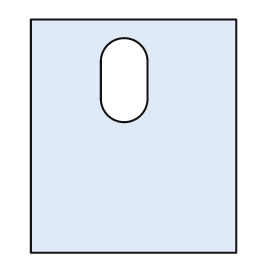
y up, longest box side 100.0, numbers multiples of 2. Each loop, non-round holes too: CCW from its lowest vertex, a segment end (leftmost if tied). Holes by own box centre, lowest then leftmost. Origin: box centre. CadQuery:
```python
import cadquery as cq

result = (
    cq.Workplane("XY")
    .moveTo(-44.0, -50.0)
    .lineTo(44.0, -50.0)
    .lineTo(44.0, 50.0)
    .lineTo(-44.0, 50.0)
    .close()
    .moveTo(-14.0, 16.0)
    .threePointArc((-4.0, 6.0), (6.0, 16.0))
    .lineTo(6.0, 32.0)
    .threePointArc((-4.0, 42.0), (-14.0, 32.0))
    .close()
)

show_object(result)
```